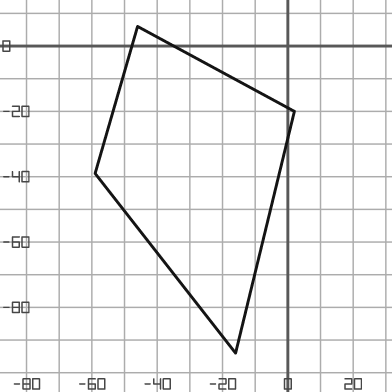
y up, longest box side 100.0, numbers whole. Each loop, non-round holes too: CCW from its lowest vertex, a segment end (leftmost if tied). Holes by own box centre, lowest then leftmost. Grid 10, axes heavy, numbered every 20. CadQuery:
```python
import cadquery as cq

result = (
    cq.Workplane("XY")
    .moveTo(-16.0, -94.0)
    .lineTo(2.0, -20.0)
    .lineTo(-46.0, 6.0)
    .lineTo(-59.0, -39.0)
    .close()
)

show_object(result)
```